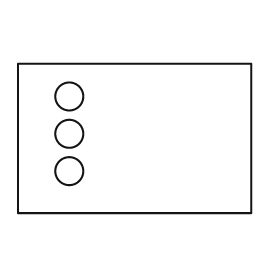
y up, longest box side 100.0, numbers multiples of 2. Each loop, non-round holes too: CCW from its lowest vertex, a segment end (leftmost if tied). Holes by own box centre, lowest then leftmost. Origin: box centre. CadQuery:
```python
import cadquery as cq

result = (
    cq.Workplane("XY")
    .moveTo(-50.0, -32.0)
    .lineTo(50.0, -32.0)
    .lineTo(50.0, 32.0)
    .lineTo(-50.0, 32.0)
    .close()
    .moveTo(-28.0, -14.0)
    .circle(6.0)
    .moveTo(-28.0, 2.0)
    .circle(6.0)
    .moveTo(-28.0, 18.0)
    .circle(6.0)
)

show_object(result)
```